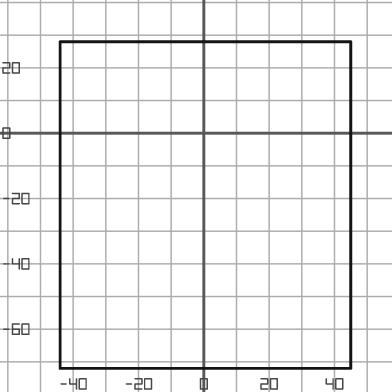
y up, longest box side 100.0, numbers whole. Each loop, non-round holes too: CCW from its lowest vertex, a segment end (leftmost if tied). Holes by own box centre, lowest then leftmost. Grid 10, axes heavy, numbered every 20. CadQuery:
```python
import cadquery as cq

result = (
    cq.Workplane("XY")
    .moveTo(-44.0, -72.0)
    .lineTo(45.0, -72.0)
    .lineTo(45.0, 28.0)
    .lineTo(-44.0, 28.0)
    .close()
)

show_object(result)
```